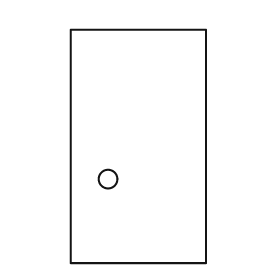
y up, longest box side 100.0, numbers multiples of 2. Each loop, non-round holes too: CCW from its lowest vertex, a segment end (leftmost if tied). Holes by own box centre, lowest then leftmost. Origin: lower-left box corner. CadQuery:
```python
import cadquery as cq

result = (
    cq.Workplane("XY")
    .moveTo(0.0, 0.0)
    .lineTo(58.0, 0.0)
    .lineTo(58.0, 100.0)
    .lineTo(0.0, 100.0)
    .close()
    .moveTo(16.0, 36.0)
    .circle(4.0)
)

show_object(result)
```